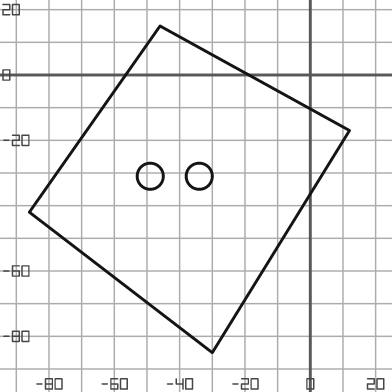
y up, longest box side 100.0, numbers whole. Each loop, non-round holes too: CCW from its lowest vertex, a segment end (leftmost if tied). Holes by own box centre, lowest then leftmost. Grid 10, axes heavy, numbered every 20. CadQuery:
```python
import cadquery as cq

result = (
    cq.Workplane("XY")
    .moveTo(-30.0, -85.0)
    .lineTo(12.0, -17.0)
    .lineTo(-46.0, 15.0)
    .lineTo(-86.0, -42.0)
    .close()
    .moveTo(-49.0, -31.0)
    .circle(4.0)
    .moveTo(-34.0, -31.0)
    .circle(4.0)
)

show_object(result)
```